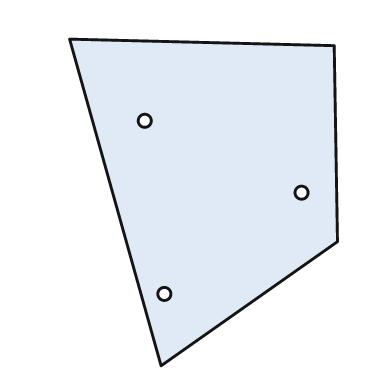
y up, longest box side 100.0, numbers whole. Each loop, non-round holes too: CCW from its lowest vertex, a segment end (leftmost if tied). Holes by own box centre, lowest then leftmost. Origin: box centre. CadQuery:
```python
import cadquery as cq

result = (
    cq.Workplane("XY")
    .moveTo(-13.0, -50.0)
    .lineTo(41.0, -12.0)
    .lineTo(40.0, 48.0)
    .lineTo(-41.0, 50.0)
    .close()
    .moveTo(-12.0, -28.0)
    .circle(2.0)
    .moveTo(30.0, 3.0)
    .circle(2.0)
    .moveTo(-18.0, 25.0)
    .circle(2.0)
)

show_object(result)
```